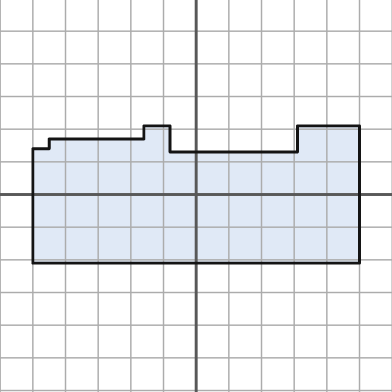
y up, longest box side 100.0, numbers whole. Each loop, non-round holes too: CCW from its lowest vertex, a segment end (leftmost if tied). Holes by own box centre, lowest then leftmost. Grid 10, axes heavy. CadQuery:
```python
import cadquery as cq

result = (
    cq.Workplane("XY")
    .moveTo(-50.0, -21.0)
    .lineTo(50.0, -21.0)
    .lineTo(50.0, 21.0)
    .lineTo(31.0, 21.0)
    .lineTo(31.0, 13.0)
    .lineTo(-8.0, 13.0)
    .lineTo(-8.0, 21.0)
    .lineTo(-16.0, 21.0)
    .lineTo(-16.0, 17.0)
    .lineTo(-45.0, 17.0)
    .lineTo(-45.0, 14.0)
    .lineTo(-50.0, 14.0)
    .close()
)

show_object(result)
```